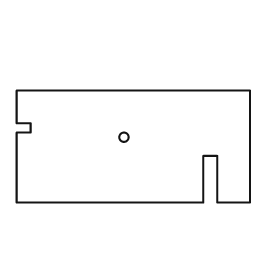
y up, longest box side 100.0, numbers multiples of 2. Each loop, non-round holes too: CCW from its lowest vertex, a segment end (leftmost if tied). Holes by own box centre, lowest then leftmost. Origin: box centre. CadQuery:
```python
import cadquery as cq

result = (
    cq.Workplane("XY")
    .moveTo(-50.0, -24.0)
    .lineTo(30.0, -24.0)
    .lineTo(30.0, -4.0)
    .lineTo(36.0, -4.0)
    .lineTo(36.0, -24.0)
    .lineTo(50.0, -24.0)
    .lineTo(50.0, 24.0)
    .lineTo(-50.0, 24.0)
    .lineTo(-50.0, 10.0)
    .lineTo(-44.0, 10.0)
    .lineTo(-44.0, 6.0)
    .lineTo(-50.0, 6.0)
    .close()
    .moveTo(-4.0, 4.0)
    .circle(2.0)
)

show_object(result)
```